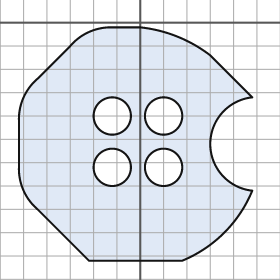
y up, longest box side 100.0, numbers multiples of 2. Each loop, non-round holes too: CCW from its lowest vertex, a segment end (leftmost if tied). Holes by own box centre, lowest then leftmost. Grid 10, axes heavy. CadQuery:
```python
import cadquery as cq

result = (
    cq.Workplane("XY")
    .moveTo(-22.0, -102.0)
    .lineTo(18.0, -102.0)
    .threePointArc((36.0, -90.0), (48.0, -72.0))
    .threePointArc((30.0, -52.0), (48.0, -32.0))
    .lineTo(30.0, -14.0)
    .threePointArc((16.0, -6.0), (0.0, -2.0))
    .lineTo(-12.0, -2.0)
    .threePointArc((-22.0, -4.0), (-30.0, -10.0))
    .lineTo(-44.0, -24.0)
    .threePointArc((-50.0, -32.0), (-52.0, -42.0))
    .lineTo(-52.0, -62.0)
    .threePointArc((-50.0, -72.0), (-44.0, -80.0))
    .close()
    .moveTo(-12.0, -62.0)
    .circle(8.0)
    .moveTo(10.0, -62.0)
    .circle(8.0)
    .moveTo(-12.0, -40.0)
    .circle(8.0)
    .moveTo(10.0, -40.0)
    .circle(8.0)
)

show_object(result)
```